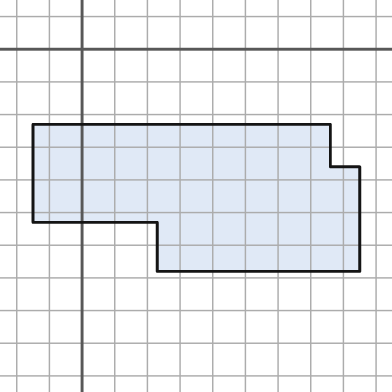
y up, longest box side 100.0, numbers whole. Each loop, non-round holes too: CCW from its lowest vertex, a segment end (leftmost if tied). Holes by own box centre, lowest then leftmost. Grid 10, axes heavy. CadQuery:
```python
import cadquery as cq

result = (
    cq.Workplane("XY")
    .moveTo(23.0, -68.0)
    .lineTo(85.0, -68.0)
    .lineTo(85.0, -36.0)
    .lineTo(76.0, -36.0)
    .lineTo(76.0, -23.0)
    .lineTo(-15.0, -23.0)
    .lineTo(-15.0, -53.0)
    .lineTo(23.0, -53.0)
    .close()
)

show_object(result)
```